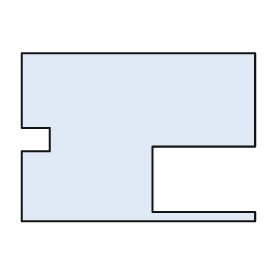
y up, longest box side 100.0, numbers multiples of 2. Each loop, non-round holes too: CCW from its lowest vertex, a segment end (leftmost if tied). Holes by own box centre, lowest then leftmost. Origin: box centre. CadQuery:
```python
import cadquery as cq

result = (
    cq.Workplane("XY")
    .moveTo(-50.0, -36.0)
    .lineTo(50.0, -36.0)
    .lineTo(50.0, -32.0)
    .lineTo(6.0, -32.0)
    .lineTo(6.0, -4.0)
    .lineTo(50.0, -4.0)
    .lineTo(50.0, 36.0)
    .lineTo(-50.0, 36.0)
    .lineTo(-50.0, 4.0)
    .lineTo(-38.0, 4.0)
    .lineTo(-38.0, -6.0)
    .lineTo(-50.0, -6.0)
    .close()
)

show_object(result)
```